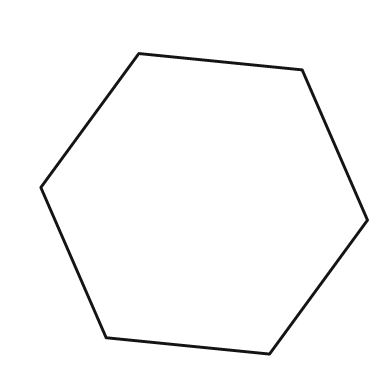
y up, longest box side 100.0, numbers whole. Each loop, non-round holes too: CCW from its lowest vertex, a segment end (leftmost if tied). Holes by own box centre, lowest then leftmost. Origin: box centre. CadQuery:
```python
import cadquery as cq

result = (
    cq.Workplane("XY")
    .moveTo(20.0, -46.0)
    .lineTo(50.0, -5.0)
    .lineTo(30.0, 41.0)
    .lineTo(-20.0, 46.0)
    .lineTo(-50.0, 5.0)
    .lineTo(-30.0, -41.0)
    .close()
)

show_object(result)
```